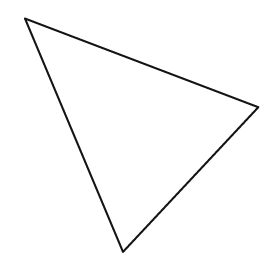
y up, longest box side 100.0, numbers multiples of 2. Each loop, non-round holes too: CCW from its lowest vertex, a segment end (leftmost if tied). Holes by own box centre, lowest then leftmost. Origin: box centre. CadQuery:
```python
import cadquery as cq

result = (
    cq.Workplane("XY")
    .moveTo(-8.0, -50.0)
    .lineTo(50.0, 12.0)
    .lineTo(-50.0, 50.0)
    .close()
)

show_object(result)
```